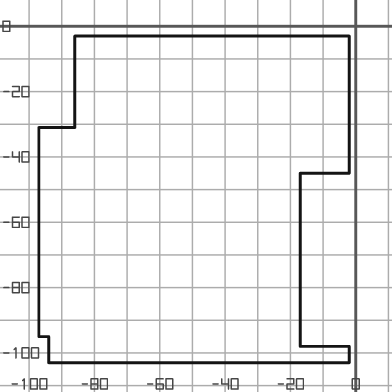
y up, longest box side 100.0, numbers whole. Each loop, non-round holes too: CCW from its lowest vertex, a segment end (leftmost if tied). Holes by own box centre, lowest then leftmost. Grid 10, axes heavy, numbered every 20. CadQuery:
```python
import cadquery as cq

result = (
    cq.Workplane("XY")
    .moveTo(-94.0, -103.0)
    .lineTo(-2.0, -103.0)
    .lineTo(-2.0, -98.0)
    .lineTo(-17.0, -98.0)
    .lineTo(-17.0, -45.0)
    .lineTo(-2.0, -45.0)
    .lineTo(-2.0, -3.0)
    .lineTo(-86.0, -3.0)
    .lineTo(-86.0, -31.0)
    .lineTo(-97.0, -31.0)
    .lineTo(-97.0, -95.0)
    .lineTo(-94.0, -95.0)
    .close()
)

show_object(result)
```